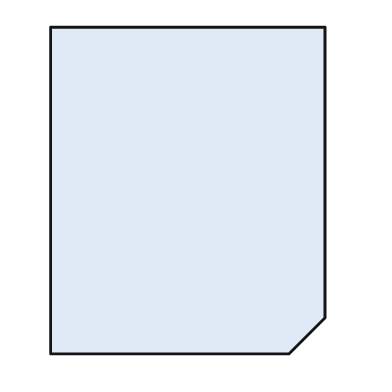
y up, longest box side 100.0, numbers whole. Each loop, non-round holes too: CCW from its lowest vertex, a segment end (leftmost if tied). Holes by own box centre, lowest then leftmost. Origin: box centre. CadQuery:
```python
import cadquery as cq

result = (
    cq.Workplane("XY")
    .moveTo(-42.0, -50.0)
    .lineTo(31.0, -50.0)
    .lineTo(42.0, -39.0)
    .lineTo(42.0, 50.0)
    .lineTo(-42.0, 50.0)
    .close()
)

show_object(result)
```